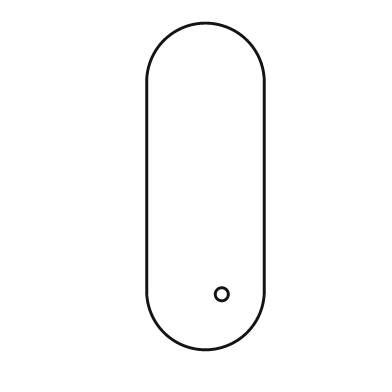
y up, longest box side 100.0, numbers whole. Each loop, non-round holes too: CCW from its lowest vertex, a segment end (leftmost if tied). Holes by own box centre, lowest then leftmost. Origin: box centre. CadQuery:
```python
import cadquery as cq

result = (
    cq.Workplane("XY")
    .moveTo(-18.0, -32.0)
    .threePointArc((0.0, -50.0), (18.0, -32.0))
    .lineTo(18.0, 32.0)
    .threePointArc((0.0, 50.0), (-18.0, 32.0))
    .close()
    .moveTo(5.0, -33.0)
    .circle(2.0)
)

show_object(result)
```